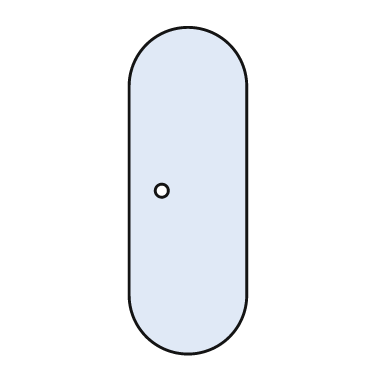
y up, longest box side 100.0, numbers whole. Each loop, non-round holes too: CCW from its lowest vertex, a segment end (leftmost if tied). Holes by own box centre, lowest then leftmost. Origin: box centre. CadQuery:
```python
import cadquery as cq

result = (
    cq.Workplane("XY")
    .moveTo(-18.0, -32.0)
    .threePointArc((0.0, -50.0), (18.0, -32.0))
    .lineTo(18.0, 32.0)
    .threePointArc((0.0, 50.0), (-18.0, 32.0))
    .close()
    .moveTo(-8.0, 0.0)
    .circle(2.0)
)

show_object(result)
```